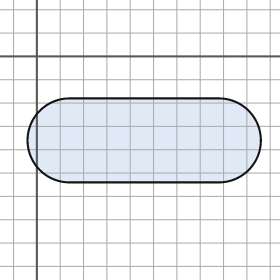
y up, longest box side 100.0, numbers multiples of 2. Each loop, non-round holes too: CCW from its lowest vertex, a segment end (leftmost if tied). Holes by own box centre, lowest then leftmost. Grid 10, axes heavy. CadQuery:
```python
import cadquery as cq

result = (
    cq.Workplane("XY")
    .moveTo(14.0, -54.0)
    .lineTo(78.0, -54.0)
    .threePointArc((96.0, -36.0), (78.0, -18.0))
    .lineTo(14.0, -18.0)
    .threePointArc((-4.0, -36.0), (14.0, -54.0))
    .close()
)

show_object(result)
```